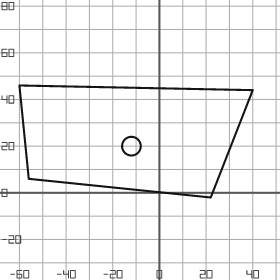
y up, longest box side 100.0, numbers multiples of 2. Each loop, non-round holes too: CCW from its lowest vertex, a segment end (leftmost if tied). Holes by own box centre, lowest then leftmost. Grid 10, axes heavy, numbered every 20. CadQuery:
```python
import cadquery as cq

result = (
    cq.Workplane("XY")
    .moveTo(22.0, -2.0)
    .lineTo(40.0, 44.0)
    .lineTo(-60.0, 46.0)
    .lineTo(-56.0, 6.0)
    .close()
    .moveTo(-12.0, 20.0)
    .circle(4.0)
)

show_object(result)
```